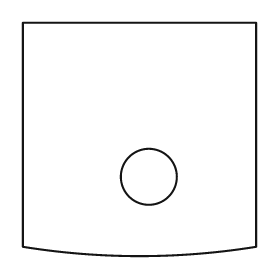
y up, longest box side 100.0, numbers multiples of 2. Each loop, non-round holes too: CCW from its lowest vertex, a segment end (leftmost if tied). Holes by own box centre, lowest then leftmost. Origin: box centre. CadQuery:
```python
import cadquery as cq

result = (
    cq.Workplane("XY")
    .moveTo(-50.0, -46.0)
    .threePointArc((0.0, -50.0), (50.0, -46.0))
    .lineTo(50.0, 50.0)
    .lineTo(-50.0, 50.0)
    .close()
    .moveTo(4.0, -16.0)
    .circle(12.0)
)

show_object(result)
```